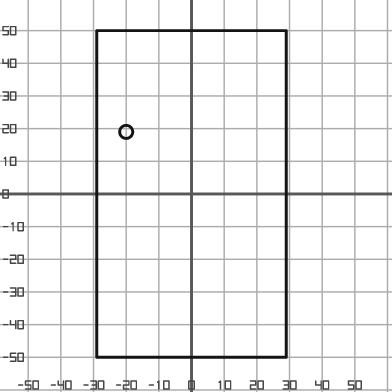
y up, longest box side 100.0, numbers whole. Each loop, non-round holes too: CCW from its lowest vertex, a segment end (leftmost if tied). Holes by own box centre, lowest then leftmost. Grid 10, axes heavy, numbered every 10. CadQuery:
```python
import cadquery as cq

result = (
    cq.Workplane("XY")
    .moveTo(-29.0, -50.0)
    .lineTo(29.0, -50.0)
    .lineTo(29.0, 50.0)
    .lineTo(-29.0, 50.0)
    .close()
    .moveTo(-20.0, 19.0)
    .circle(2.0)
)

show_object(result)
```